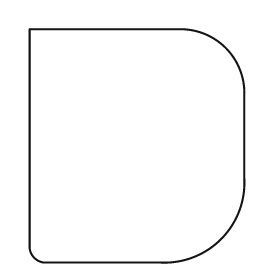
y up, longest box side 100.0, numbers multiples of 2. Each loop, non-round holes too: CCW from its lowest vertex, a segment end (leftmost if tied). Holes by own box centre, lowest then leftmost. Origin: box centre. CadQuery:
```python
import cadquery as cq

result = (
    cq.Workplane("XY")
    .moveTo(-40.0, -50.0)
    .lineTo(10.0, -50.0)
    .threePointArc((36.0, -40.0), (46.0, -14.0))
    .lineTo(46.0, 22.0)
    .threePointArc((38.0, 42.0), (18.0, 50.0))
    .lineTo(-46.0, 50.0)
    .lineTo(-46.0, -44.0)
    .threePointArc((-44.0, -48.0), (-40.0, -50.0))
    .close()
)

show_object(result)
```